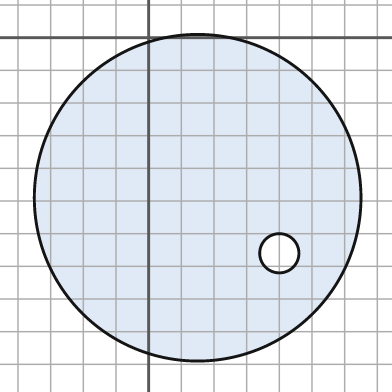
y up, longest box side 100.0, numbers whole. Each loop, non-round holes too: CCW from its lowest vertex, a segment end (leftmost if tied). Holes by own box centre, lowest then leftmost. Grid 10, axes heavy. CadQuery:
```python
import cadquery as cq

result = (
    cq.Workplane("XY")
    .moveTo(15.0, -49.0)
    .circle(50.0)
    .moveTo(40.0, -66.0)
    .circle(6.0)
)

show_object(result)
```